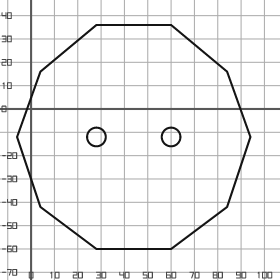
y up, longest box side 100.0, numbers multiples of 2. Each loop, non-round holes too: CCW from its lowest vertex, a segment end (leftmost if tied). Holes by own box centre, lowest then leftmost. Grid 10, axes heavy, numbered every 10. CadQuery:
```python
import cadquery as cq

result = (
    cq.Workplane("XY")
    .moveTo(28.0, -60.0)
    .lineTo(60.0, -60.0)
    .lineTo(84.0, -42.0)
    .lineTo(94.0, -12.0)
    .lineTo(84.0, 16.0)
    .lineTo(60.0, 36.0)
    .lineTo(28.0, 36.0)
    .lineTo(4.0, 16.0)
    .lineTo(-6.0, -12.0)
    .lineTo(4.0, -42.0)
    .close()
    .moveTo(28.0, -12.0)
    .circle(4.0)
    .moveTo(60.0, -12.0)
    .circle(4.0)
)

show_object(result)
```